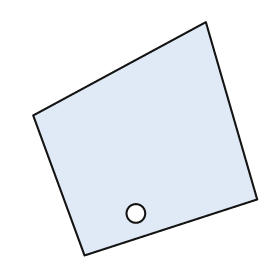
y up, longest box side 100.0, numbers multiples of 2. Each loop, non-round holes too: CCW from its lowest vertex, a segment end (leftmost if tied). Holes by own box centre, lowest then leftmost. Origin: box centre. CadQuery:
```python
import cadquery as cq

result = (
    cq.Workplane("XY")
    .moveTo(-26.0, -50.0)
    .lineTo(48.0, -26.0)
    .lineTo(26.0, 50.0)
    .lineTo(-48.0, 10.0)
    .close()
    .moveTo(-4.0, -32.0)
    .circle(4.0)
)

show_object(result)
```